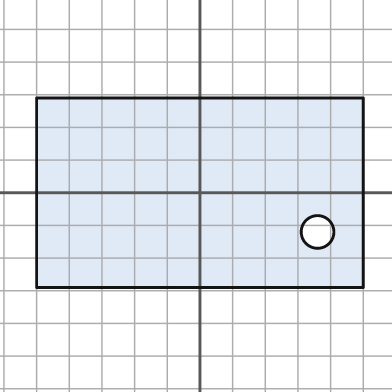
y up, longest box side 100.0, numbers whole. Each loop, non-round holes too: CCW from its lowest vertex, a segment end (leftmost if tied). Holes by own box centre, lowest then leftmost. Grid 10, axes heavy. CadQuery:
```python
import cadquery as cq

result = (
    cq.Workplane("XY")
    .moveTo(-50.0, -29.0)
    .lineTo(50.0, -29.0)
    .lineTo(50.0, 29.0)
    .lineTo(-50.0, 29.0)
    .close()
    .moveTo(36.0, -12.0)
    .circle(5.0)
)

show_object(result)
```